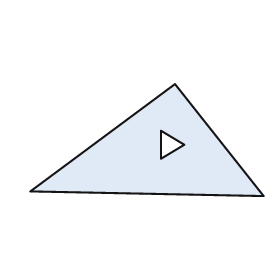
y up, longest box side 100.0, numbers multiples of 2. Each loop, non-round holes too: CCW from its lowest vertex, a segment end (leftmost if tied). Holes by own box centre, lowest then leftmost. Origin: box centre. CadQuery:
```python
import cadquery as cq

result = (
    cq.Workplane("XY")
    .moveTo(50.0, -24.0)
    .lineTo(12.0, 24.0)
    .lineTo(-50.0, -22.0)
    .close()
    .moveTo(6.0, -8.0)
    .lineTo(16.0, -2.0)
    .lineTo(6.0, 4.0)
    .close()
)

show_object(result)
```